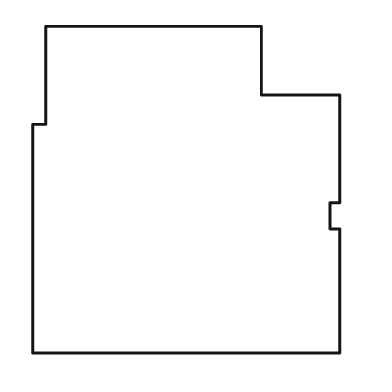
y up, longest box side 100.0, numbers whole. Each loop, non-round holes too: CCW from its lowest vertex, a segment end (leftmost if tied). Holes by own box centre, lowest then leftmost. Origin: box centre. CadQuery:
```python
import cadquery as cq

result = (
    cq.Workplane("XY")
    .moveTo(-47.0, -50.0)
    .lineTo(47.0, -50.0)
    .lineTo(47.0, -12.0)
    .lineTo(44.0, -12.0)
    .lineTo(44.0, -4.0)
    .lineTo(47.0, -4.0)
    .lineTo(47.0, 29.0)
    .lineTo(23.0, 29.0)
    .lineTo(23.0, 50.0)
    .lineTo(-43.0, 50.0)
    .lineTo(-43.0, 20.0)
    .lineTo(-47.0, 20.0)
    .close()
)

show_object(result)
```